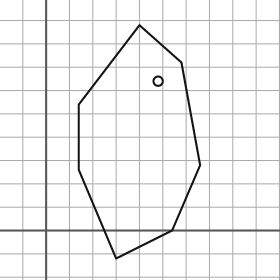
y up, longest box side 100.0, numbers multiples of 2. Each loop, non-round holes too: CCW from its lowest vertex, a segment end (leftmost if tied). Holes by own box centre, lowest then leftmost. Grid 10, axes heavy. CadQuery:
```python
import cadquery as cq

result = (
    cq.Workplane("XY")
    .moveTo(30.0, -12.0)
    .lineTo(54.0, 0.0)
    .lineTo(66.0, 28.0)
    .lineTo(58.0, 72.0)
    .lineTo(40.0, 88.0)
    .lineTo(14.0, 54.0)
    .lineTo(14.0, 26.0)
    .close()
    .moveTo(48.0, 64.0)
    .circle(2.0)
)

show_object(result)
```